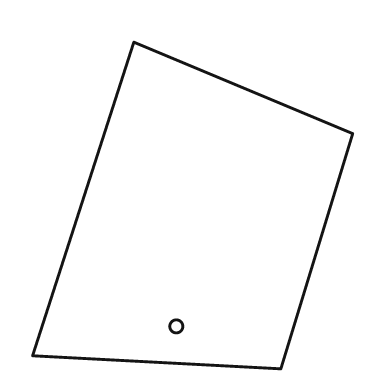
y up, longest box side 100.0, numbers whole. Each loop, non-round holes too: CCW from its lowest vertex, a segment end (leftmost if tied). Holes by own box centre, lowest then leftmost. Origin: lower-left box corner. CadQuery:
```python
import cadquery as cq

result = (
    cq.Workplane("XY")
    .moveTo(76.0, 0.0)
    .lineTo(98.0, 72.0)
    .lineTo(31.0, 100.0)
    .lineTo(0.0, 4.0)
    .close()
    .moveTo(44.0, 13.0)
    .circle(2.0)
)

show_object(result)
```